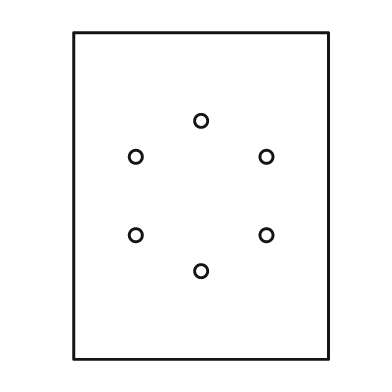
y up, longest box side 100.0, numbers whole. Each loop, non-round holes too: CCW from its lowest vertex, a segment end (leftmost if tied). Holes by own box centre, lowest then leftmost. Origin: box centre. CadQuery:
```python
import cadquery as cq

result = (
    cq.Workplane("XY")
    .moveTo(-39.0, -50.0)
    .lineTo(39.0, -50.0)
    .lineTo(39.0, 50.0)
    .lineTo(-39.0, 50.0)
    .close()
    .moveTo(0.0, -23.0)
    .circle(2.0)
    .moveTo(-20.0, -12.0)
    .circle(2.0)
    .moveTo(20.0, -12.0)
    .circle(2.0)
    .moveTo(-20.0, 12.0)
    .circle(2.0)
    .moveTo(20.0, 12.0)
    .circle(2.0)
    .moveTo(0.0, 23.0)
    .circle(2.0)
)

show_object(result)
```